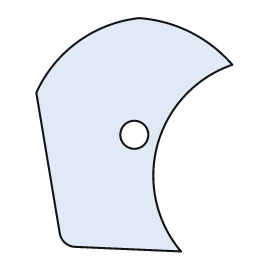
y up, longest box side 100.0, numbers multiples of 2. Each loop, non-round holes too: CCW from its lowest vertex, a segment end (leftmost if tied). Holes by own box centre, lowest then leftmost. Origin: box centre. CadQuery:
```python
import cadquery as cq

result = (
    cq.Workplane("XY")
    .moveTo(20.0, -50.0)
    .threePointArc((10.0, -4.0), (42.0, 30.0))
    .threePointArc((24.0, 44.0), (2.0, 50.0))
    .threePointArc((-24.0, 40.0), (-42.0, 18.0))
    .lineTo(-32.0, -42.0)
    .threePointArc((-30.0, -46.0), (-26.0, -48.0))
    .close()
    .moveTo(0.0, 0.0)
    .circle(6.0)
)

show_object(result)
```